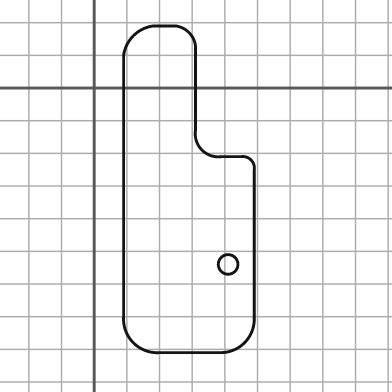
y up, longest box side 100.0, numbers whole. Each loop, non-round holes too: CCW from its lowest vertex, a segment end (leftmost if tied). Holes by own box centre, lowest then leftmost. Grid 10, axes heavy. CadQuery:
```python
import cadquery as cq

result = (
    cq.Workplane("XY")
    .moveTo(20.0, -81.0)
    .lineTo(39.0, -81.0)
    .threePointArc((46.0, -78.0), (49.0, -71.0))
    .lineTo(49.0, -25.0)
    .threePointArc((48.0, -22.0), (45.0, -21.0))
    .lineTo(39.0, -21.0)
    .threePointArc((33.0, -19.0), (31.0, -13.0))
    .lineTo(31.0, 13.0)
    .threePointArc((29.0, 17.0), (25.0, 19.0))
    .lineTo(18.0, 19.0)
    .threePointArc((12.0, 16.0), (9.0, 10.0))
    .lineTo(9.0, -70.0)
    .threePointArc((12.0, -78.0), (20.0, -81.0))
    .close()
    .moveTo(41.0, -54.0)
    .circle(3.0)
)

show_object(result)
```